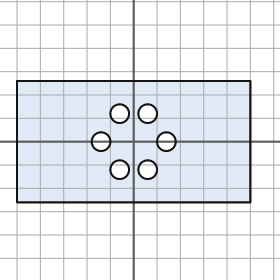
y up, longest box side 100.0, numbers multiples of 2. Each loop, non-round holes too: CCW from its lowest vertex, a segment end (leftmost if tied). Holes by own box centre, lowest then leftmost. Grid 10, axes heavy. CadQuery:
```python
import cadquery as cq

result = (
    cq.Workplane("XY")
    .moveTo(-50.0, -26.0)
    .lineTo(50.0, -26.0)
    .lineTo(50.0, 26.0)
    .lineTo(-50.0, 26.0)
    .close()
    .moveTo(-6.0, -12.0)
    .circle(4.0)
    .moveTo(6.0, -12.0)
    .circle(4.0)
    .moveTo(-14.0, 0.0)
    .circle(4.0)
    .moveTo(14.0, 0.0)
    .circle(4.0)
    .moveTo(-6.0, 12.0)
    .circle(4.0)
    .moveTo(6.0, 12.0)
    .circle(4.0)
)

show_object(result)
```